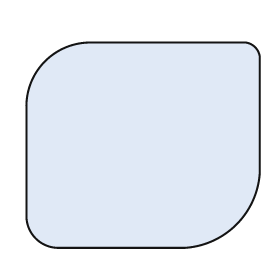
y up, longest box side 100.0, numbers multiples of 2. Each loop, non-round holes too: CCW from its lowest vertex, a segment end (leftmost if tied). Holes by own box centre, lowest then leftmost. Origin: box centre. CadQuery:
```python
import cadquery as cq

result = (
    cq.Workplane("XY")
    .moveTo(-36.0, -44.0)
    .lineTo(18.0, -44.0)
    .threePointArc((40.0, -34.0), (50.0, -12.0))
    .lineTo(50.0, 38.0)
    .threePointArc((48.0, 42.0), (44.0, 44.0))
    .lineTo(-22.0, 44.0)
    .threePointArc((-42.0, 36.0), (-50.0, 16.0))
    .lineTo(-50.0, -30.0)
    .threePointArc((-46.0, -40.0), (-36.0, -44.0))
    .close()
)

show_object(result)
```